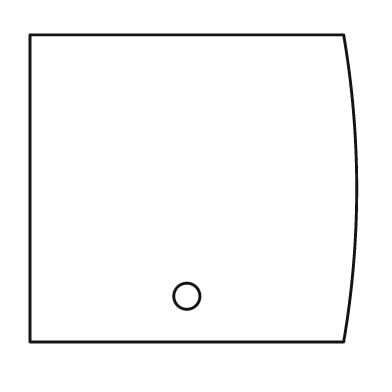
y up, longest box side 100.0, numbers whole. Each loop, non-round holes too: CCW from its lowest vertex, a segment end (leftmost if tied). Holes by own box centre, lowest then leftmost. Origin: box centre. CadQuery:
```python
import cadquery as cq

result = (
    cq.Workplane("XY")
    .moveTo(-50.0, -47.0)
    .lineTo(46.0, -47.0)
    .threePointArc((50.0, 0.0), (46.0, 47.0))
    .lineTo(-50.0, 47.0)
    .close()
    .moveTo(-2.0, -33.0)
    .circle(4.0)
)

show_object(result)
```